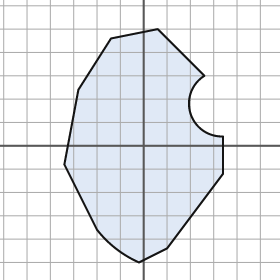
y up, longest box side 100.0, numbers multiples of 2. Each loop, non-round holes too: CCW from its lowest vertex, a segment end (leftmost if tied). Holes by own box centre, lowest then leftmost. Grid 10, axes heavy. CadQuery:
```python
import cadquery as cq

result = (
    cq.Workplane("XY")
    .moveTo(-2.0, -50.0)
    .lineTo(10.0, -44.0)
    .lineTo(34.0, -12.0)
    .lineTo(34.0, 4.0)
    .threePointArc((20.0, 14.0), (26.0, 30.0))
    .lineTo(6.0, 50.0)
    .lineTo(-14.0, 46.0)
    .lineTo(-28.0, 24.0)
    .lineTo(-34.0, -8.0)
    .lineTo(-20.0, -36.0)
    .threePointArc((-12.0, -44.0), (-2.0, -50.0))
    .close()
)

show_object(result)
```